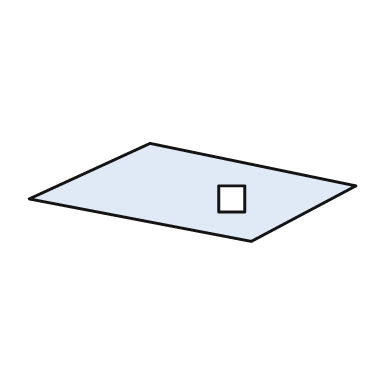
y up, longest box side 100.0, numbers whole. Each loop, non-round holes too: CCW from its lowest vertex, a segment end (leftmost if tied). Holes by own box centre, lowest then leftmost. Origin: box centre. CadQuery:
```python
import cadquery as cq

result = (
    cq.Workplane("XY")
    .moveTo(18.0, -15.0)
    .lineTo(50.0, 2.0)
    .lineTo(-13.0, 15.0)
    .lineTo(-50.0, -2.0)
    .close()
    .moveTo(8.0, -6.0)
    .lineTo(16.0, -6.0)
    .lineTo(16.0, 2.0)
    .lineTo(8.0, 2.0)
    .close()
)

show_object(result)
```